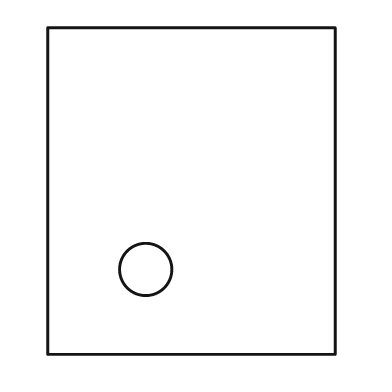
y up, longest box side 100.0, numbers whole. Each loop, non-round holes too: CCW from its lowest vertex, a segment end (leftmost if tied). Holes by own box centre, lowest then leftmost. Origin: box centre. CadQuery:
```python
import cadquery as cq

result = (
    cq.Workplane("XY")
    .moveTo(-44.0, -50.0)
    .lineTo(44.0, -50.0)
    .lineTo(44.0, 50.0)
    .lineTo(-44.0, 50.0)
    .close()
    .moveTo(-14.0, -24.0)
    .circle(8.0)
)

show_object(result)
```